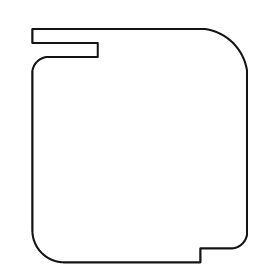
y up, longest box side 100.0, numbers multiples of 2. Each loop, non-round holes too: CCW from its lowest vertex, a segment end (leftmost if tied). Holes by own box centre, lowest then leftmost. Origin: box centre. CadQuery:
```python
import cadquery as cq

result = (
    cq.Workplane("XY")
    .moveTo(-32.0, -50.0)
    .lineTo(26.0, -50.0)
    .lineTo(26.0, -44.0)
    .lineTo(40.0, -44.0)
    .threePointArc((44.0, -42.0), (46.0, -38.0))
    .lineTo(46.0, 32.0)
    .threePointArc((40.0, 44.0), (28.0, 50.0))
    .lineTo(-46.0, 50.0)
    .lineTo(-46.0, 44.0)
    .lineTo(-18.0, 44.0)
    .lineTo(-18.0, 38.0)
    .lineTo(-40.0, 38.0)
    .threePointArc((-44.0, 36.0), (-46.0, 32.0))
    .lineTo(-46.0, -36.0)
    .threePointArc((-42.0, -46.0), (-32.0, -50.0))
    .close()
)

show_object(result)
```